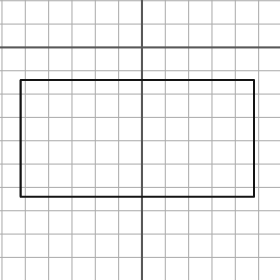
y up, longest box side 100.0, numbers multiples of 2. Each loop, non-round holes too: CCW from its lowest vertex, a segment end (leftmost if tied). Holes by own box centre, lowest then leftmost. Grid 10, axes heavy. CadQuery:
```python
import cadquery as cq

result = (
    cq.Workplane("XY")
    .moveTo(-52.0, -64.0)
    .lineTo(48.0, -64.0)
    .lineTo(48.0, -14.0)
    .lineTo(-52.0, -14.0)
    .close()
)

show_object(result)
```